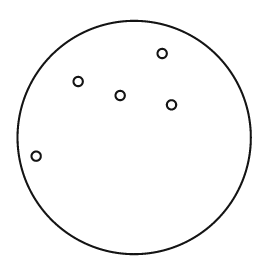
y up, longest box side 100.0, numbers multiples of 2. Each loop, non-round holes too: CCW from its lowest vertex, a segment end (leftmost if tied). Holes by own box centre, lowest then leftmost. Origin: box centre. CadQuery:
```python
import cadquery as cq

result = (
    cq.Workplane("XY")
    .moveTo(0.0, 0.0)
    .circle(50.0)
    .moveTo(-42.0, -8.0)
    .circle(2.0)
    .moveTo(16.0, 14.0)
    .circle(2.0)
    .moveTo(-6.0, 18.0)
    .circle(2.0)
    .moveTo(-24.0, 24.0)
    .circle(2.0)
    .moveTo(12.0, 36.0)
    .circle(2.0)
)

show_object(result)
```